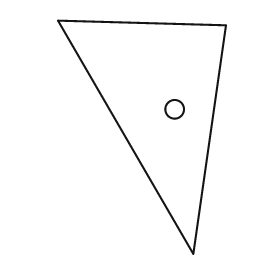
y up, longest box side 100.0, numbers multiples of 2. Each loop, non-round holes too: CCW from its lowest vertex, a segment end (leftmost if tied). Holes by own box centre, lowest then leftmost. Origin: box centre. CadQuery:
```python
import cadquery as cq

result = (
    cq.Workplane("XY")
    .moveTo(22.0, -50.0)
    .lineTo(36.0, 48.0)
    .lineTo(-36.0, 50.0)
    .close()
    .moveTo(14.0, 12.0)
    .circle(4.0)
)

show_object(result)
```